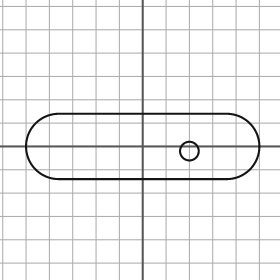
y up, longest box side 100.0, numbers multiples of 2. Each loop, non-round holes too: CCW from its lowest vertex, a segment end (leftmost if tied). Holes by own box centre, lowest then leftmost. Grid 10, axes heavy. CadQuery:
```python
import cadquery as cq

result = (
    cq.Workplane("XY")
    .moveTo(-36.0, -14.0)
    .lineTo(36.0, -14.0)
    .threePointArc((50.0, 0.0), (36.0, 14.0))
    .lineTo(-36.0, 14.0)
    .threePointArc((-50.0, 0.0), (-36.0, -14.0))
    .close()
    .moveTo(20.0, -2.0)
    .circle(4.0)
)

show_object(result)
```